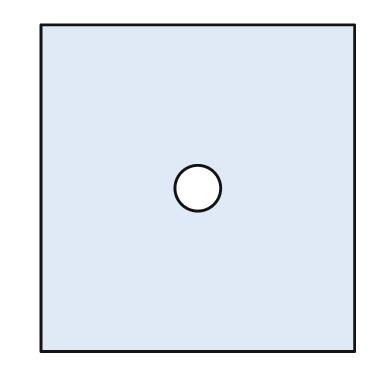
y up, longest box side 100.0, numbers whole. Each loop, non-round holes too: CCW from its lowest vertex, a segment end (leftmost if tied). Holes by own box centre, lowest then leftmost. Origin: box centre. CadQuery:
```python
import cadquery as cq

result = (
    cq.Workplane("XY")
    .moveTo(-48.0, -50.0)
    .lineTo(48.0, -50.0)
    .lineTo(48.0, 50.0)
    .lineTo(-48.0, 50.0)
    .close()
    .moveTo(0.0, 0.0)
    .circle(7.0)
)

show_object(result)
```